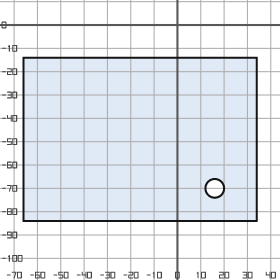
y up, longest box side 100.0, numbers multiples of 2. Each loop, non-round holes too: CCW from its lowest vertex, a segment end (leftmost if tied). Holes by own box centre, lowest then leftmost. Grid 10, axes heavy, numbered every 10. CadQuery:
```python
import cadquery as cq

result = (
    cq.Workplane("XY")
    .moveTo(-66.0, -84.0)
    .lineTo(34.0, -84.0)
    .lineTo(34.0, -14.0)
    .lineTo(-66.0, -14.0)
    .close()
    .moveTo(16.0, -70.0)
    .circle(4.0)
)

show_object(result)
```